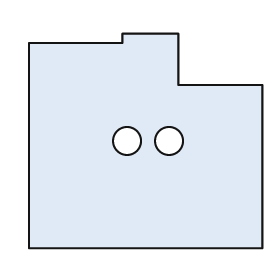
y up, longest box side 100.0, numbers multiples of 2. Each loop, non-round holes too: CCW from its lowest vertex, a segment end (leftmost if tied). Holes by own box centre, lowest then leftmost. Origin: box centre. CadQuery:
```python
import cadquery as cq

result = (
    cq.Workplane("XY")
    .moveTo(-50.0, -46.0)
    .lineTo(50.0, -46.0)
    .lineTo(50.0, 24.0)
    .lineTo(14.0, 24.0)
    .lineTo(14.0, 46.0)
    .lineTo(-10.0, 46.0)
    .lineTo(-10.0, 42.0)
    .lineTo(-50.0, 42.0)
    .close()
    .moveTo(-8.0, 0.0)
    .circle(6.0)
    .moveTo(10.0, 0.0)
    .circle(6.0)
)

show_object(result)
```